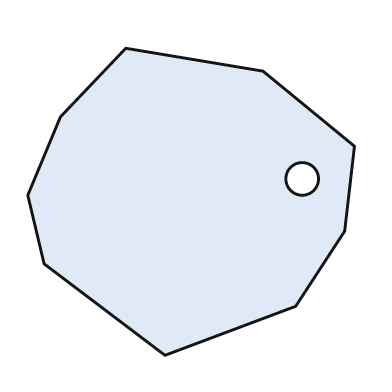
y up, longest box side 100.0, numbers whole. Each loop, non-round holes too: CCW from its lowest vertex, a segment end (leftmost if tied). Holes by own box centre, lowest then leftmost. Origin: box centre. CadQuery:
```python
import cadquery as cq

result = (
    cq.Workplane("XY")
    .moveTo(-8.0, -47.0)
    .lineTo(32.0, -32.0)
    .lineTo(47.0, -9.0)
    .lineTo(50.0, 17.0)
    .lineTo(22.0, 40.0)
    .lineTo(-20.0, 47.0)
    .lineTo(-40.0, 26.0)
    .lineTo(-50.0, 2.0)
    .lineTo(-45.0, -19.0)
    .close()
    .moveTo(34.0, 7.0)
    .circle(5.0)
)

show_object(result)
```